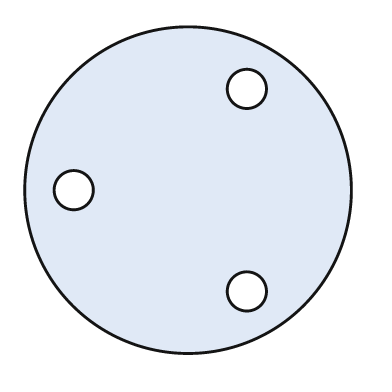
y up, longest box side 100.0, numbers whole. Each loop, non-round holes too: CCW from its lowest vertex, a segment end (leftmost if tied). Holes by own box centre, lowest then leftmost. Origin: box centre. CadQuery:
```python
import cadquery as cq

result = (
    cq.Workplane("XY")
    .moveTo(0.0, 0.0)
    .circle(50.0)
    .moveTo(18.0, -31.0)
    .circle(6.0)
    .moveTo(-35.0, 0.0)
    .circle(6.0)
    .moveTo(18.0, 31.0)
    .circle(6.0)
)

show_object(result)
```